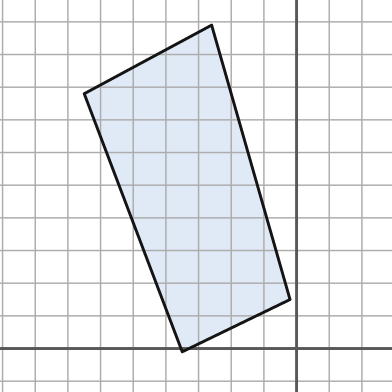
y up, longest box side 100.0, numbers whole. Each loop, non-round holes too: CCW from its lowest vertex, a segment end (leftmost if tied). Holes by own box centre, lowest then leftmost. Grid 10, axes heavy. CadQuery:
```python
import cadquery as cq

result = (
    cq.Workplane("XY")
    .moveTo(-35.0, -1.0)
    .lineTo(-2.0, 15.0)
    .lineTo(-26.0, 99.0)
    .lineTo(-65.0, 78.0)
    .close()
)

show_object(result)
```